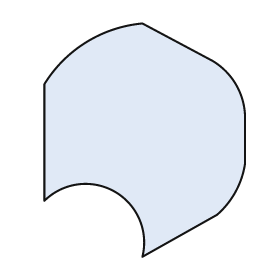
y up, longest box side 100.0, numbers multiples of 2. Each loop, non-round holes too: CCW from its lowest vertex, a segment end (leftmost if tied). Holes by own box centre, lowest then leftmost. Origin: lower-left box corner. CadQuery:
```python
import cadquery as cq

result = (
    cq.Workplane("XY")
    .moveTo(42.0, 0.0)
    .lineTo(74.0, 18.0)
    .threePointArc((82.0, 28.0), (86.0, 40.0))
    .lineTo(86.0, 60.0)
    .threePointArc((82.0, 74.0), (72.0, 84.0))
    .lineTo(42.0, 100.0)
    .threePointArc((18.0, 92.0), (0.0, 74.0))
    .lineTo(0.0, 24.0)
    .threePointArc((30.0, 28.0), (42.0, 0.0))
    .close()
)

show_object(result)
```